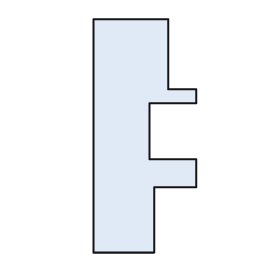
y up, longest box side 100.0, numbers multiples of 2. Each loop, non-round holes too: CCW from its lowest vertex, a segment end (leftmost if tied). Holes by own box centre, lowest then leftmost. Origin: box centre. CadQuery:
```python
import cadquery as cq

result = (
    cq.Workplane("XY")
    .moveTo(-22.0, -50.0)
    .lineTo(4.0, -50.0)
    .lineTo(4.0, -22.0)
    .lineTo(22.0, -22.0)
    .lineTo(22.0, -10.0)
    .lineTo(2.0, -10.0)
    .lineTo(2.0, 14.0)
    .lineTo(22.0, 14.0)
    .lineTo(22.0, 20.0)
    .lineTo(10.0, 20.0)
    .lineTo(10.0, 50.0)
    .lineTo(-22.0, 50.0)
    .close()
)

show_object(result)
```